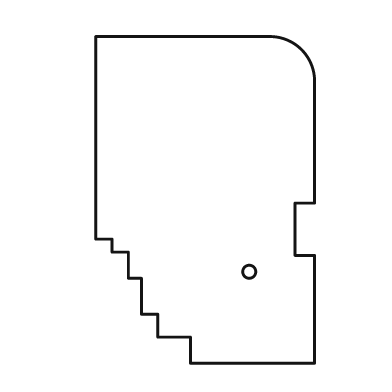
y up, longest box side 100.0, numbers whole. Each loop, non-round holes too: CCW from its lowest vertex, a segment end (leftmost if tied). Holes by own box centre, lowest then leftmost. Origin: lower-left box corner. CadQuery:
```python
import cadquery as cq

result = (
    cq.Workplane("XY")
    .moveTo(29.0, 0.0)
    .lineTo(67.0, 0.0)
    .lineTo(67.0, 33.0)
    .lineTo(61.0, 33.0)
    .lineTo(61.0, 49.0)
    .lineTo(67.0, 49.0)
    .lineTo(67.0, 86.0)
    .threePointArc((63.0, 96.0), (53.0, 100.0))
    .lineTo(0.0, 100.0)
    .lineTo(0.0, 38.0)
    .lineTo(5.0, 38.0)
    .lineTo(5.0, 34.0)
    .lineTo(10.0, 34.0)
    .lineTo(10.0, 26.0)
    .lineTo(14.0, 26.0)
    .lineTo(14.0, 15.0)
    .lineTo(19.0, 15.0)
    .lineTo(19.0, 8.0)
    .lineTo(29.0, 8.0)
    .close()
    .moveTo(47.0, 28.0)
    .circle(2.0)
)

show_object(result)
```